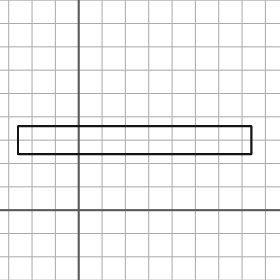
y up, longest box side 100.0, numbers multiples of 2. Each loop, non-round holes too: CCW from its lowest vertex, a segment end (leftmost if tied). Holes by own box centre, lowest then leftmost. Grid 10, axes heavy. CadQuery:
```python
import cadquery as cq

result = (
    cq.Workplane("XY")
    .moveTo(-26.0, 24.0)
    .lineTo(74.0, 24.0)
    .lineTo(74.0, 36.0)
    .lineTo(-26.0, 36.0)
    .close()
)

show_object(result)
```